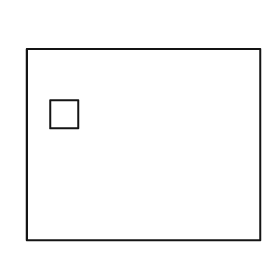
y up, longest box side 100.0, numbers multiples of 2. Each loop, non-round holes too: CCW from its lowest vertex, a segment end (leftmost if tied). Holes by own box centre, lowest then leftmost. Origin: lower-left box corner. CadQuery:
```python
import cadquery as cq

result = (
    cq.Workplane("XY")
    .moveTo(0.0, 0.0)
    .lineTo(100.0, 0.0)
    .lineTo(100.0, 82.0)
    .lineTo(0.0, 82.0)
    .close()
    .moveTo(10.0, 48.0)
    .lineTo(22.0, 48.0)
    .lineTo(22.0, 60.0)
    .lineTo(10.0, 60.0)
    .close()
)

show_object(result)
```